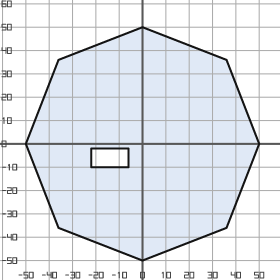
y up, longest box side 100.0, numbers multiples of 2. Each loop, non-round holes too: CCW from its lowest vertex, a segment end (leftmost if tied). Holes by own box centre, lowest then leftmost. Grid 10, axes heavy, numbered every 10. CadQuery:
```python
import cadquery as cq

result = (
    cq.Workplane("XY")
    .moveTo(0.0, -50.0)
    .lineTo(36.0, -36.0)
    .lineTo(50.0, 0.0)
    .lineTo(36.0, 36.0)
    .lineTo(0.0, 50.0)
    .lineTo(-36.0, 36.0)
    .lineTo(-50.0, 0.0)
    .lineTo(-36.0, -36.0)
    .close()
    .moveTo(-22.0, -10.0)
    .lineTo(-6.0, -10.0)
    .lineTo(-6.0, -2.0)
    .lineTo(-22.0, -2.0)
    .close()
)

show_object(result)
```